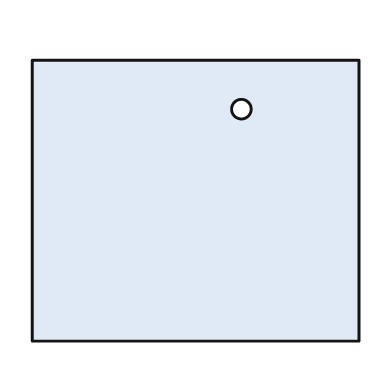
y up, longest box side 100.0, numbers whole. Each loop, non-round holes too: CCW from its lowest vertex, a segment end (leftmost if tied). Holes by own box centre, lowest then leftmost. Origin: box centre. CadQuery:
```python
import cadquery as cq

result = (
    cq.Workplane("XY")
    .moveTo(-50.0, -43.0)
    .lineTo(50.0, -43.0)
    .lineTo(50.0, 43.0)
    .lineTo(-50.0, 43.0)
    .close()
    .moveTo(14.0, 28.0)
    .circle(3.0)
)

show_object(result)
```